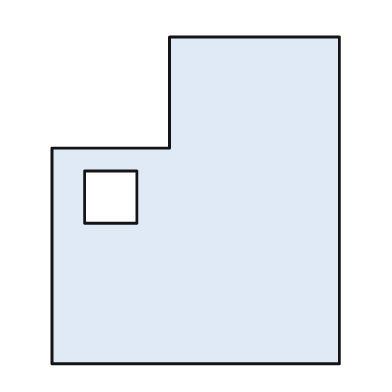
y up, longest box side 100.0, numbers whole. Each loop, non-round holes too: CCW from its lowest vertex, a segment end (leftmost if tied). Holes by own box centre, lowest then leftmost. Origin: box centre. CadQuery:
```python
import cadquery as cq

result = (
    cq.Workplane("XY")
    .moveTo(-44.0, -50.0)
    .lineTo(44.0, -50.0)
    .lineTo(44.0, 50.0)
    .lineTo(-8.0, 50.0)
    .lineTo(-8.0, 16.0)
    .lineTo(-44.0, 16.0)
    .close()
    .moveTo(-34.0, -7.0)
    .lineTo(-18.0, -7.0)
    .lineTo(-18.0, 9.0)
    .lineTo(-34.0, 9.0)
    .close()
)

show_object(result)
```